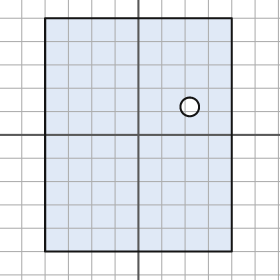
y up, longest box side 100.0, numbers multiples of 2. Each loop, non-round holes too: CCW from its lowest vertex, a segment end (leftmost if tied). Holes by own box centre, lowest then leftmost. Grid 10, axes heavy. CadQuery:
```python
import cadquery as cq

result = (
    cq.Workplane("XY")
    .moveTo(-40.0, -50.0)
    .lineTo(40.0, -50.0)
    .lineTo(40.0, 50.0)
    .lineTo(-40.0, 50.0)
    .close()
    .moveTo(22.0, 12.0)
    .circle(4.0)
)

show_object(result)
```